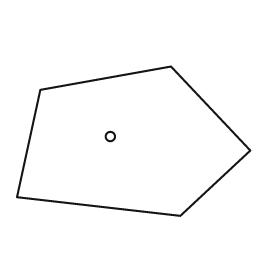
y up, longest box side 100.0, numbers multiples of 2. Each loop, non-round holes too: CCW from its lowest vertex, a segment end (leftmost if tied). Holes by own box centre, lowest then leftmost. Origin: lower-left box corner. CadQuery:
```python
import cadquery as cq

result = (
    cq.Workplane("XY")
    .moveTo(70.0, 0.0)
    .lineTo(100.0, 28.0)
    .lineTo(66.0, 64.0)
    .lineTo(10.0, 54.0)
    .lineTo(0.0, 8.0)
    .close()
    .moveTo(40.0, 34.0)
    .circle(2.0)
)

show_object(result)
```